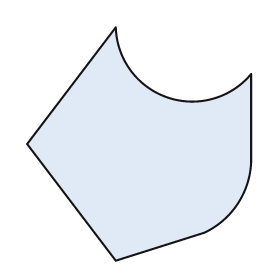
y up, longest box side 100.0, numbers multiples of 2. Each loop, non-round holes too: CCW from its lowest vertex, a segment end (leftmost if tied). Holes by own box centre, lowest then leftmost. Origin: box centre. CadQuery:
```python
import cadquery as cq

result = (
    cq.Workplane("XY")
    .moveTo(-10.0, -50.0)
    .lineTo(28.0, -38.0)
    .threePointArc((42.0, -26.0), (48.0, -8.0))
    .lineTo(48.0, 30.0)
    .threePointArc((12.0, 20.0), (-10.0, 50.0))
    .lineTo(-48.0, 0.0)
    .close()
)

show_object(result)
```